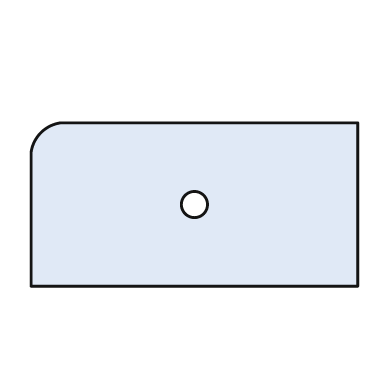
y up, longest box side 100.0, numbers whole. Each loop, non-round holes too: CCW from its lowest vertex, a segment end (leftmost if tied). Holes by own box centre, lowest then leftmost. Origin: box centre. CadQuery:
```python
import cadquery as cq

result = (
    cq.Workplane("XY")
    .moveTo(-50.0, -25.0)
    .lineTo(50.0, -25.0)
    .lineTo(50.0, 25.0)
    .lineTo(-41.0, 25.0)
    .threePointArc((-47.0, 22.0), (-50.0, 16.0))
    .close()
    .moveTo(0.0, 0.0)
    .circle(4.0)
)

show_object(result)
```